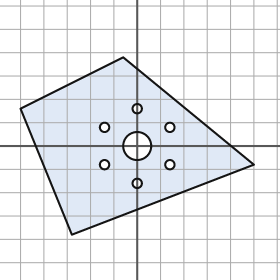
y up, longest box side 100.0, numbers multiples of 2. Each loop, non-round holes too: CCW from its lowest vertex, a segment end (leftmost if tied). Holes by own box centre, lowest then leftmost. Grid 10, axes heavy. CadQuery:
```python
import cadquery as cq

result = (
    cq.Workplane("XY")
    .moveTo(-28.0, -38.0)
    .lineTo(50.0, -8.0)
    .lineTo(-6.0, 38.0)
    .lineTo(-50.0, 16.0)
    .close()
    .moveTo(0.0, -16.0)
    .circle(2.0)
    .moveTo(-14.0, -8.0)
    .circle(2.0)
    .moveTo(14.0, -8.0)
    .circle(2.0)
    .moveTo(0.0, 0.0)
    .circle(6.0)
    .moveTo(-14.0, 8.0)
    .circle(2.0)
    .moveTo(14.0, 8.0)
    .circle(2.0)
    .moveTo(0.0, 16.0)
    .circle(2.0)
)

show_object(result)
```